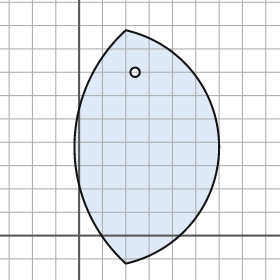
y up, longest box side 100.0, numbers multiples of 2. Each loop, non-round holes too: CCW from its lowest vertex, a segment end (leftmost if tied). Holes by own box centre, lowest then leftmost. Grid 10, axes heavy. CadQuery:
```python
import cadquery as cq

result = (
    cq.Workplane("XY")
    .moveTo(20.0, -12.0)
    .threePointArc((60.0, 38.0), (20.0, 88.0))
    .threePointArc((-2.0, 38.0), (20.0, -12.0))
    .close()
    .moveTo(24.0, 70.0)
    .circle(2.0)
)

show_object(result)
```